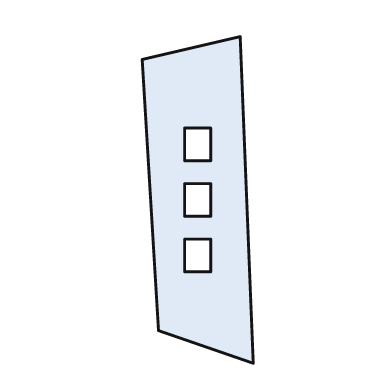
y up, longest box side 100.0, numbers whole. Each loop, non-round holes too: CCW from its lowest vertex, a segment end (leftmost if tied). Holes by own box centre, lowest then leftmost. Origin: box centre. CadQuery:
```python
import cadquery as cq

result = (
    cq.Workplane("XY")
    .moveTo(17.0, -50.0)
    .lineTo(13.0, 50.0)
    .lineTo(-17.0, 43.0)
    .lineTo(-12.0, -40.0)
    .close()
    .moveTo(-4.0, -22.0)
    .lineTo(4.0, -22.0)
    .lineTo(4.0, -12.0)
    .lineTo(-4.0, -12.0)
    .close()
    .moveTo(-4.0, -5.0)
    .lineTo(4.0, -5.0)
    .lineTo(4.0, 5.0)
    .lineTo(-4.0, 5.0)
    .close()
    .moveTo(-4.0, 12.0)
    .lineTo(4.0, 12.0)
    .lineTo(4.0, 22.0)
    .lineTo(-4.0, 22.0)
    .close()
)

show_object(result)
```